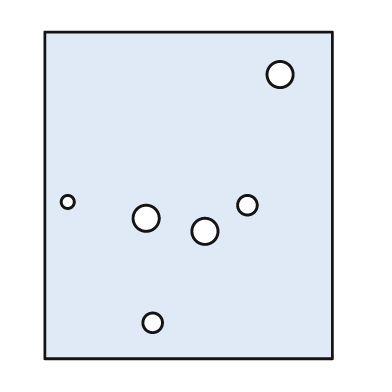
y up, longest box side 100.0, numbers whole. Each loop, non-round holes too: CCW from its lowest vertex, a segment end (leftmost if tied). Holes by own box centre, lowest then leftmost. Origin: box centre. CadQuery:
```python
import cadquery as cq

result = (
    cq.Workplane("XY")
    .moveTo(-44.0, -50.0)
    .lineTo(44.0, -50.0)
    .lineTo(44.0, 50.0)
    .lineTo(-44.0, 50.0)
    .close()
    .moveTo(-11.0, -39.0)
    .circle(3.0)
    .moveTo(5.0, -11.0)
    .circle(4.0)
    .moveTo(-13.0, -7.0)
    .circle(4.0)
    .moveTo(18.0, -3.0)
    .circle(3.0)
    .moveTo(-37.0, -2.0)
    .circle(2.0)
    .moveTo(28.0, 37.0)
    .circle(4.0)
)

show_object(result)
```